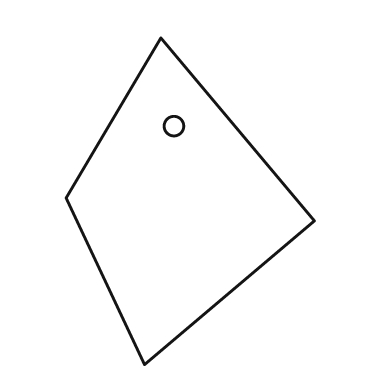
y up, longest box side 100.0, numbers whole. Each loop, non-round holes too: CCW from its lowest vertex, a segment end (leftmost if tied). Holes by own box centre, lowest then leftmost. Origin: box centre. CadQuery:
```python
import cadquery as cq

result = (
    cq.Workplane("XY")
    .moveTo(-14.0, -50.0)
    .lineTo(38.0, -6.0)
    .lineTo(-9.0, 50.0)
    .lineTo(-38.0, 1.0)
    .close()
    .moveTo(-5.0, 23.0)
    .circle(3.0)
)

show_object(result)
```